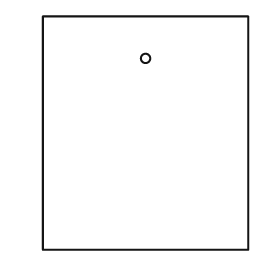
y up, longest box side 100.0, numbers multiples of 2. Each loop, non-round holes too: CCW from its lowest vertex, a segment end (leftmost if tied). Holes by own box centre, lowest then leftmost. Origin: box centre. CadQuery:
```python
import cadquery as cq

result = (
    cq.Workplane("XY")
    .moveTo(-44.0, -50.0)
    .lineTo(44.0, -50.0)
    .lineTo(44.0, 50.0)
    .lineTo(-44.0, 50.0)
    .close()
    .moveTo(0.0, 32.0)
    .circle(2.0)
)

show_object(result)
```